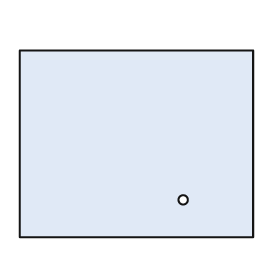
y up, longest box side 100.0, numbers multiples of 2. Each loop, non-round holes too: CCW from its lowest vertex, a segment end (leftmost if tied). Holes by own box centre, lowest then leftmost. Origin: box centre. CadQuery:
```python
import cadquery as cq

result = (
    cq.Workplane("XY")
    .moveTo(-50.0, -40.0)
    .lineTo(50.0, -40.0)
    .lineTo(50.0, 40.0)
    .lineTo(-50.0, 40.0)
    .close()
    .moveTo(20.0, -24.0)
    .circle(2.0)
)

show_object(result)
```